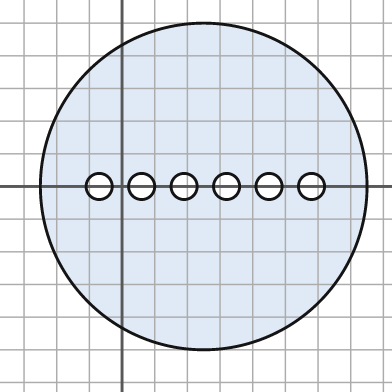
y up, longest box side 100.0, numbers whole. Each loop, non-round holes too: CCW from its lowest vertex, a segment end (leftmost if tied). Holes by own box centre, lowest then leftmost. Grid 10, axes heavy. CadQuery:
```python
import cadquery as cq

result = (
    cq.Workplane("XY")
    .moveTo(25.0, 0.0)
    .circle(50.0)
    .moveTo(-7.0, 0.0)
    .circle(4.0)
    .moveTo(6.0, 0.0)
    .circle(4.0)
    .moveTo(19.0, 0.0)
    .circle(4.0)
    .moveTo(32.0, 0.0)
    .circle(4.0)
    .moveTo(45.0, 0.0)
    .circle(4.0)
    .moveTo(58.0, 0.0)
    .circle(4.0)
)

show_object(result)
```